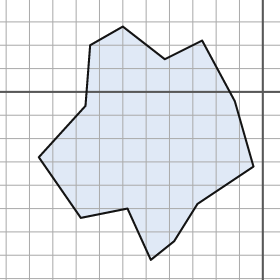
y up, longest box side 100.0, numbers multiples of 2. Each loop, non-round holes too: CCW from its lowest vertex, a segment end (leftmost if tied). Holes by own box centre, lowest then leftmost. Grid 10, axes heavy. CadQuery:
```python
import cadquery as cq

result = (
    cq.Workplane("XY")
    .moveTo(-48.0, -72.0)
    .lineTo(-38.0, -64.0)
    .lineTo(-28.0, -48.0)
    .lineTo(-4.0, -32.0)
    .lineTo(-12.0, -4.0)
    .lineTo(-26.0, 22.0)
    .lineTo(-42.0, 14.0)
    .lineTo(-60.0, 28.0)
    .lineTo(-74.0, 20.0)
    .lineTo(-76.0, -6.0)
    .lineTo(-96.0, -28.0)
    .lineTo(-78.0, -54.0)
    .lineTo(-58.0, -50.0)
    .close()
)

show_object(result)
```